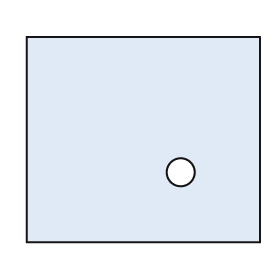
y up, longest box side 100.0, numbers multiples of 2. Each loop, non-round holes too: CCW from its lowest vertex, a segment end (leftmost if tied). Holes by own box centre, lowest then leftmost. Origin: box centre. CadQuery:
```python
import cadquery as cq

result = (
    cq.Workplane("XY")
    .moveTo(-50.0, -44.0)
    .lineTo(50.0, -44.0)
    .lineTo(50.0, 44.0)
    .lineTo(-50.0, 44.0)
    .close()
    .moveTo(16.0, -14.0)
    .circle(6.0)
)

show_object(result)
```